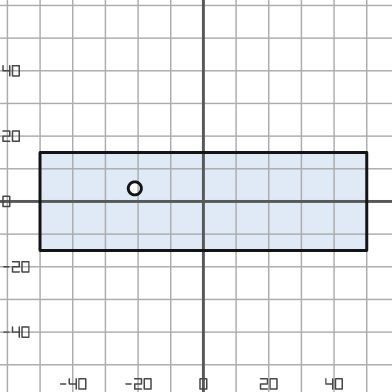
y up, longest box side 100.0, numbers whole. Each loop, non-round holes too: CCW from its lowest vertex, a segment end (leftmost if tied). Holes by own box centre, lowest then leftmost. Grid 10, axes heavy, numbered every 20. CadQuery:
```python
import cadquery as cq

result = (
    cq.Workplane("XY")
    .moveTo(-50.0, -15.0)
    .lineTo(50.0, -15.0)
    .lineTo(50.0, 15.0)
    .lineTo(-50.0, 15.0)
    .close()
    .moveTo(-21.0, 4.0)
    .circle(2.0)
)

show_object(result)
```